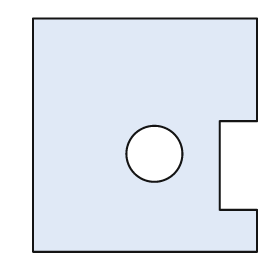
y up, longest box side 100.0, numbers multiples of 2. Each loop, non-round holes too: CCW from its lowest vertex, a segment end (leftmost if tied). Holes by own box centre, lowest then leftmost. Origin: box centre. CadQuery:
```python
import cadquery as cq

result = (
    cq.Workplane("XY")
    .moveTo(-48.0, -50.0)
    .lineTo(48.0, -50.0)
    .lineTo(48.0, -32.0)
    .lineTo(32.0, -32.0)
    .lineTo(32.0, 6.0)
    .lineTo(48.0, 6.0)
    .lineTo(48.0, 50.0)
    .lineTo(-48.0, 50.0)
    .close()
    .moveTo(4.0, -8.0)
    .circle(12.0)
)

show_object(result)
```